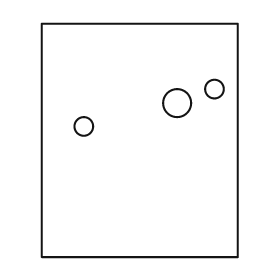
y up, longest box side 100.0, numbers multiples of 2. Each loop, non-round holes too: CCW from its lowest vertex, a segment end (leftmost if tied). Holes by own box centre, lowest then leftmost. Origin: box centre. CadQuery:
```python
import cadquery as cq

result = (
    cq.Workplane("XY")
    .moveTo(-42.0, -50.0)
    .lineTo(42.0, -50.0)
    .lineTo(42.0, 50.0)
    .lineTo(-42.0, 50.0)
    .close()
    .moveTo(-24.0, 6.0)
    .circle(4.0)
    .moveTo(16.0, 16.0)
    .circle(6.0)
    .moveTo(32.0, 22.0)
    .circle(4.0)
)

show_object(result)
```